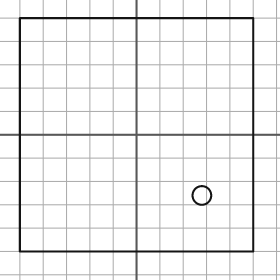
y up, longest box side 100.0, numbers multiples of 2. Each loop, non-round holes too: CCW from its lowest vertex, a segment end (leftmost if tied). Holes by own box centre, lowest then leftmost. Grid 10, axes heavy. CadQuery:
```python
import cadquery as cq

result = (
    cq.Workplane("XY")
    .moveTo(-50.0, -50.0)
    .lineTo(50.0, -50.0)
    .lineTo(50.0, 50.0)
    .lineTo(-50.0, 50.0)
    .close()
    .moveTo(28.0, -26.0)
    .circle(4.0)
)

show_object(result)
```